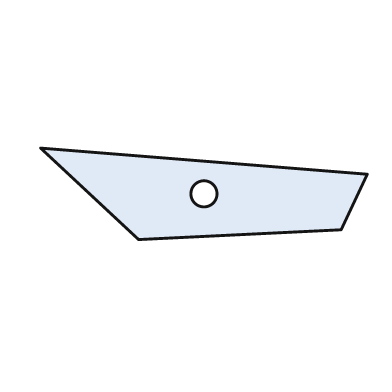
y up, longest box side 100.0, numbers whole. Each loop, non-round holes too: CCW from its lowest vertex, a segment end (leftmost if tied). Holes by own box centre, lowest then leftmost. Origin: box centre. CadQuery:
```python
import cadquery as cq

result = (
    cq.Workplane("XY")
    .moveTo(-20.0, -14.0)
    .lineTo(42.0, -11.0)
    .lineTo(50.0, 6.0)
    .lineTo(-50.0, 14.0)
    .close()
    .moveTo(0.0, 0.0)
    .circle(4.0)
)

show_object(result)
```